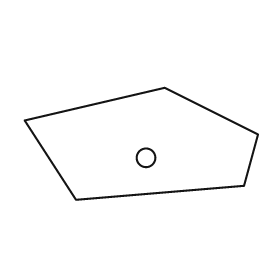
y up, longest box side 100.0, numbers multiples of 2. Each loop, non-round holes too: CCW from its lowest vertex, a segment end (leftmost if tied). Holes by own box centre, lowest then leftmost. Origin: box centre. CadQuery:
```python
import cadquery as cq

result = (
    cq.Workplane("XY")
    .moveTo(-28.0, -24.0)
    .lineTo(44.0, -18.0)
    .lineTo(50.0, 4.0)
    .lineTo(10.0, 24.0)
    .lineTo(-50.0, 10.0)
    .close()
    .moveTo(2.0, -6.0)
    .circle(4.0)
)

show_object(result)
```